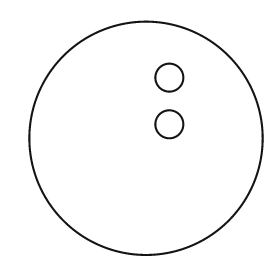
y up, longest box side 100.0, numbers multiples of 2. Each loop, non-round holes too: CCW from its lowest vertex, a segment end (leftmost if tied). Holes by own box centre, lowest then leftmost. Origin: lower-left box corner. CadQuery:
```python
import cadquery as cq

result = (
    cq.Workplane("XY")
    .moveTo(50.0, 50.0)
    .circle(50.0)
    .moveTo(60.0, 56.0)
    .circle(6.0)
    .moveTo(60.0, 76.0)
    .circle(6.0)
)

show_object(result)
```